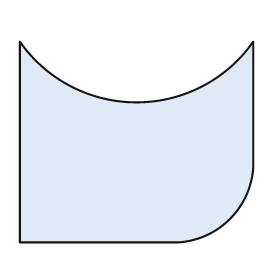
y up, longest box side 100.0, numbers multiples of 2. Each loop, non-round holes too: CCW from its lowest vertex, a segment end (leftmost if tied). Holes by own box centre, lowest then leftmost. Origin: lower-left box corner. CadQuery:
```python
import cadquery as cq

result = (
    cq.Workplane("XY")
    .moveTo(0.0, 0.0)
    .lineTo(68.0, 0.0)
    .threePointArc((90.0, 10.0), (100.0, 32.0))
    .lineTo(100.0, 86.0)
    .threePointArc((50.0, 60.0), (0.0, 86.0))
    .close()
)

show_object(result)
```